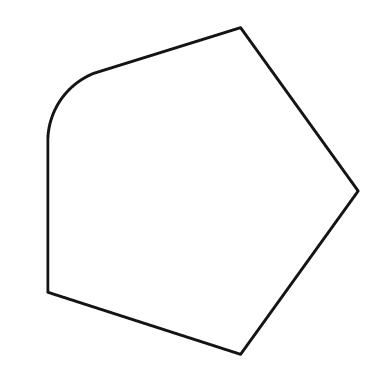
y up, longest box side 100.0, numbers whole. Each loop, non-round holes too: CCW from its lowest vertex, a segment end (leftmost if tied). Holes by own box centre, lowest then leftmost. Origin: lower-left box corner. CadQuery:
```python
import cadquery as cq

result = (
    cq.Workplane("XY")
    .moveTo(59.0, 0.0)
    .lineTo(95.0, 50.0)
    .lineTo(59.0, 100.0)
    .lineTo(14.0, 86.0)
    .threePointArc((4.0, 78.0), (0.0, 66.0))
    .lineTo(0.0, 19.0)
    .close()
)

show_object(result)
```